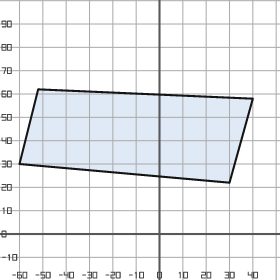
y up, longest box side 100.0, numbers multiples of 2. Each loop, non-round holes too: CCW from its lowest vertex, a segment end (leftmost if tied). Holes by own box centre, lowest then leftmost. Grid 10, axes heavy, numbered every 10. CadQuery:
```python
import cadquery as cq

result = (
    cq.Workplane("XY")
    .moveTo(30.0, 22.0)
    .lineTo(40.0, 58.0)
    .lineTo(-52.0, 62.0)
    .lineTo(-60.0, 30.0)
    .close()
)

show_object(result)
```